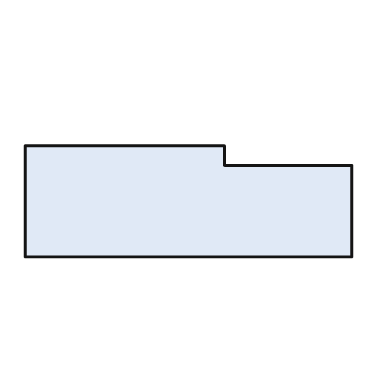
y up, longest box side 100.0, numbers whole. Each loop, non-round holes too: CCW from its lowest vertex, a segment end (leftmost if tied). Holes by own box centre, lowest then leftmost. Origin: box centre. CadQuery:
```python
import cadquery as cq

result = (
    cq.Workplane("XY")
    .moveTo(-50.0, -17.0)
    .lineTo(50.0, -17.0)
    .lineTo(50.0, 11.0)
    .lineTo(11.0, 11.0)
    .lineTo(11.0, 17.0)
    .lineTo(-50.0, 17.0)
    .close()
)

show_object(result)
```